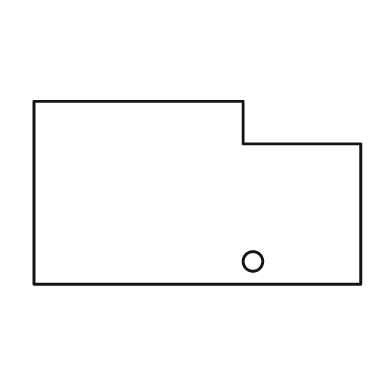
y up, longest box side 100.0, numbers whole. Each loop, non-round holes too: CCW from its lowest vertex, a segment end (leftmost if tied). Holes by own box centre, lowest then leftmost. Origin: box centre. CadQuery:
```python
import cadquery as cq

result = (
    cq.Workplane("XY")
    .moveTo(-50.0, -28.0)
    .lineTo(50.0, -28.0)
    .lineTo(50.0, 15.0)
    .lineTo(14.0, 15.0)
    .lineTo(14.0, 28.0)
    .lineTo(-50.0, 28.0)
    .close()
    .moveTo(17.0, -21.0)
    .circle(3.0)
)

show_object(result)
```